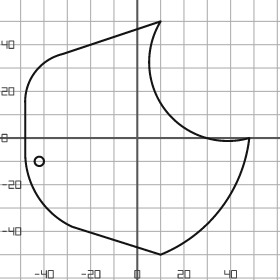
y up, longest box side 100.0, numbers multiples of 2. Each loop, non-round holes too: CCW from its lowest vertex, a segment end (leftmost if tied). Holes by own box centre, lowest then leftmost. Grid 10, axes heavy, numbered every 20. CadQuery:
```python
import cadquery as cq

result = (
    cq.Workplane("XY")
    .moveTo(10.0, -50.0)
    .threePointArc((36.0, -30.0), (48.0, 0.0))
    .threePointArc((12.0, 12.0), (10.0, 50.0))
    .lineTo(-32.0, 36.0)
    .threePointArc((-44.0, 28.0), (-48.0, 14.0))
    .lineTo(-48.0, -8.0)
    .threePointArc((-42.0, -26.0), (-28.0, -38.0))
    .close()
    .moveTo(-42.0, -10.0)
    .circle(2.0)
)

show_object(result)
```